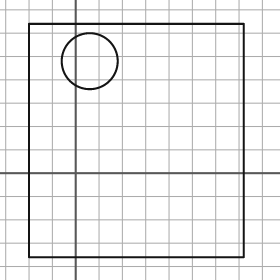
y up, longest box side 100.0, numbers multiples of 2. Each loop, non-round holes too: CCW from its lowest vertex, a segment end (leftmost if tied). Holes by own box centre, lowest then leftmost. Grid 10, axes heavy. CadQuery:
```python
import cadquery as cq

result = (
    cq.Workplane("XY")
    .moveTo(-20.0, -36.0)
    .lineTo(72.0, -36.0)
    .lineTo(72.0, 64.0)
    .lineTo(-20.0, 64.0)
    .close()
    .moveTo(6.0, 48.0)
    .circle(12.0)
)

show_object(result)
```